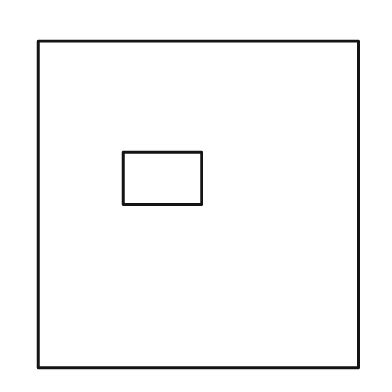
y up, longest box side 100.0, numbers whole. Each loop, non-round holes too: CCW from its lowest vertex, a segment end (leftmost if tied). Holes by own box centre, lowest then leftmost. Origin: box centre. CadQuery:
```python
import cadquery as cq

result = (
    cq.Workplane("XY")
    .moveTo(-49.0, -50.0)
    .lineTo(49.0, -50.0)
    .lineTo(49.0, 50.0)
    .lineTo(-49.0, 50.0)
    .close()
    .moveTo(-23.0, 0.0)
    .lineTo(1.0, 0.0)
    .lineTo(1.0, 16.0)
    .lineTo(-23.0, 16.0)
    .close()
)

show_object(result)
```